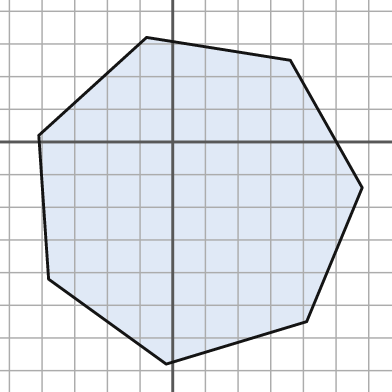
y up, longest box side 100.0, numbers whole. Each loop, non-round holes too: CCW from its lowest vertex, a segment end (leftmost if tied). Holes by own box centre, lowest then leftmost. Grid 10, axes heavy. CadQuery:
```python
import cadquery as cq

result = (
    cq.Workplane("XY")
    .moveTo(-2.0, -68.0)
    .lineTo(41.0, -55.0)
    .lineTo(58.0, -14.0)
    .lineTo(36.0, 25.0)
    .lineTo(-8.0, 32.0)
    .lineTo(-41.0, 2.0)
    .lineTo(-38.0, -42.0)
    .close()
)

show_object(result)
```